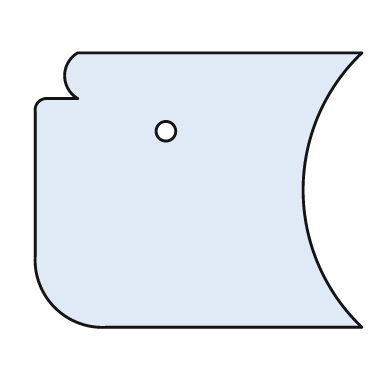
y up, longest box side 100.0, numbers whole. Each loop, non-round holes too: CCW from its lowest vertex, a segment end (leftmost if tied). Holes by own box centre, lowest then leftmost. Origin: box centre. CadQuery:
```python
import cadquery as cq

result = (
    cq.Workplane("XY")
    .moveTo(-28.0, -42.0)
    .lineTo(50.0, -42.0)
    .threePointArc((32.0, 0.0), (50.0, 42.0))
    .lineTo(-37.0, 42.0)
    .threePointArc((-41.0, 35.0), (-37.0, 28.0))
    .lineTo(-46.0, 28.0)
    .threePointArc((-49.0, 27.0), (-50.0, 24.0))
    .lineTo(-50.0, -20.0)
    .threePointArc((-44.0, -36.0), (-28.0, -42.0))
    .close()
    .moveTo(-10.0, 18.0)
    .circle(3.0)
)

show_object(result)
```